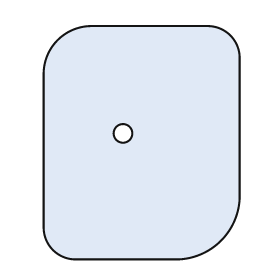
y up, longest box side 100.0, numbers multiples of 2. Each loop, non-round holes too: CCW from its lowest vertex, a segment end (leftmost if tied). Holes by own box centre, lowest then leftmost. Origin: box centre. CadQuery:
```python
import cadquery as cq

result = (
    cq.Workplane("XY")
    .moveTo(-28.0, -50.0)
    .lineTo(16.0, -50.0)
    .threePointArc((34.0, -42.0), (42.0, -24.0))
    .lineTo(42.0, 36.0)
    .threePointArc((38.0, 46.0), (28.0, 50.0))
    .lineTo(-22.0, 50.0)
    .threePointArc((-36.0, 44.0), (-42.0, 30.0))
    .lineTo(-42.0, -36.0)
    .threePointArc((-38.0, -46.0), (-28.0, -50.0))
    .close()
    .moveTo(-8.0, 4.0)
    .circle(4.0)
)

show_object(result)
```